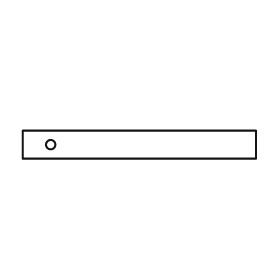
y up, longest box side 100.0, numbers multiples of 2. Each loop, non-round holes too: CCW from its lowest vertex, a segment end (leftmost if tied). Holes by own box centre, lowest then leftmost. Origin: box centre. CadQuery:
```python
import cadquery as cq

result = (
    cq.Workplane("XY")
    .moveTo(-50.0, -6.0)
    .lineTo(50.0, -6.0)
    .lineTo(50.0, 6.0)
    .lineTo(-50.0, 6.0)
    .close()
    .moveTo(-38.0, 0.0)
    .circle(2.0)
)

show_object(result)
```